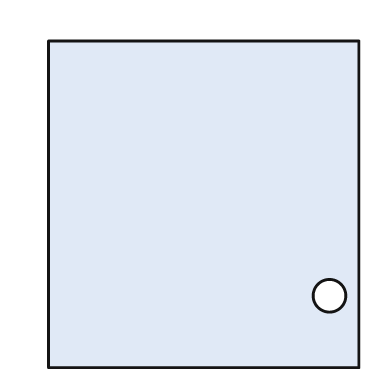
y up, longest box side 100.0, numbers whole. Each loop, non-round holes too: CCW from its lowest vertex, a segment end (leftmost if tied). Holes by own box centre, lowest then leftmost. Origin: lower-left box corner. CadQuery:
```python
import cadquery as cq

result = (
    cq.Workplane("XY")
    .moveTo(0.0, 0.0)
    .lineTo(95.0, 0.0)
    .lineTo(95.0, 100.0)
    .lineTo(0.0, 100.0)
    .close()
    .moveTo(86.0, 22.0)
    .circle(5.0)
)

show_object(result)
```